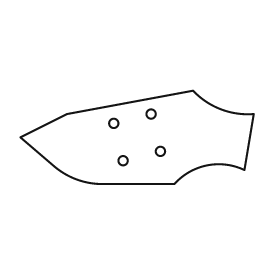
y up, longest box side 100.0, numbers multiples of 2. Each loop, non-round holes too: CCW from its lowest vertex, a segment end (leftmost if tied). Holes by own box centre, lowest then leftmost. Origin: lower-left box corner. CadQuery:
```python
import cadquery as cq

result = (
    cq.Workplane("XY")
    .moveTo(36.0, 0.0)
    .lineTo(66.0, 0.0)
    .threePointArc((80.0, 8.0), (96.0, 6.0))
    .lineTo(100.0, 30.0)
    .threePointArc((86.0, 32.0), (74.0, 40.0))
    .lineTo(20.0, 30.0)
    .lineTo(0.0, 20.0)
    .lineTo(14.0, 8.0)
    .threePointArc((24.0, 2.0), (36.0, 0.0))
    .close()
    .moveTo(44.0, 10.0)
    .circle(2.0)
    .moveTo(60.0, 14.0)
    .circle(2.0)
    .moveTo(40.0, 26.0)
    .circle(2.0)
    .moveTo(56.0, 30.0)
    .circle(2.0)
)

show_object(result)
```